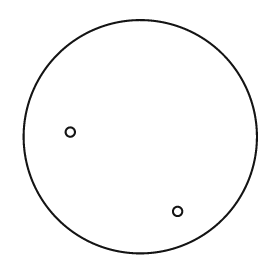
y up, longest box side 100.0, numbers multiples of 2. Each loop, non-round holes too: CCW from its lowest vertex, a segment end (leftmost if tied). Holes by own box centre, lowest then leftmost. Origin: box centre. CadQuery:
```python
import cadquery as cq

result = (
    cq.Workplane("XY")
    .moveTo(0.0, 0.0)
    .circle(50.0)
    .moveTo(16.0, -32.0)
    .circle(2.0)
    .moveTo(-30.0, 2.0)
    .circle(2.0)
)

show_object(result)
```